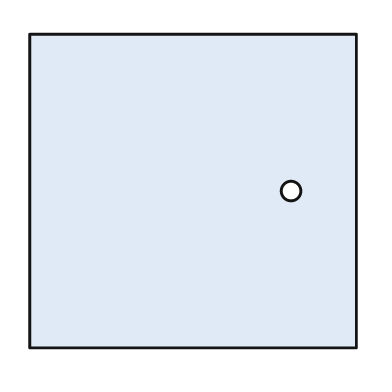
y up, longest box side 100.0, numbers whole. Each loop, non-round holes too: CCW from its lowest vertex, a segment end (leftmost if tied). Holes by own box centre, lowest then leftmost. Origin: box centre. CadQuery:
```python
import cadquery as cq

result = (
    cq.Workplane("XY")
    .moveTo(-50.0, -48.0)
    .lineTo(50.0, -48.0)
    .lineTo(50.0, 48.0)
    .lineTo(-50.0, 48.0)
    .close()
    .moveTo(30.0, 0.0)
    .circle(3.0)
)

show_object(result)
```